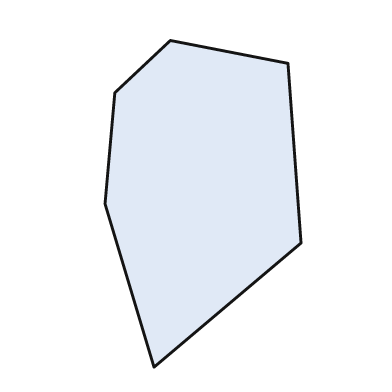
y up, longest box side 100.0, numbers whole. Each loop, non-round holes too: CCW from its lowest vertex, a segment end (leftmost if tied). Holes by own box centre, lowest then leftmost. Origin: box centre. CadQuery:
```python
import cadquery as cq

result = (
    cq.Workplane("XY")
    .moveTo(-15.0, -50.0)
    .lineTo(30.0, -12.0)
    .lineTo(26.0, 43.0)
    .lineTo(-10.0, 50.0)
    .lineTo(-27.0, 34.0)
    .lineTo(-30.0, 0.0)
    .close()
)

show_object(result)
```